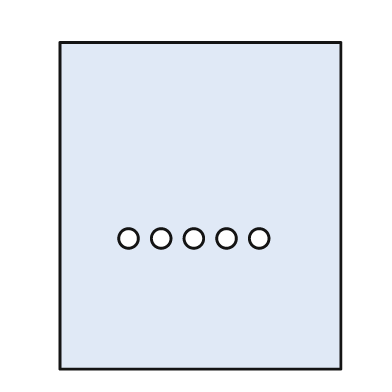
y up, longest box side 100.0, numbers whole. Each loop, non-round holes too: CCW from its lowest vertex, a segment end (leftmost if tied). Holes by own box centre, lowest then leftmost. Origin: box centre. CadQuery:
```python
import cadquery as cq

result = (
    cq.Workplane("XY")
    .moveTo(-43.0, -50.0)
    .lineTo(43.0, -50.0)
    .lineTo(43.0, 50.0)
    .lineTo(-43.0, 50.0)
    .close()
    .moveTo(-22.0, -10.0)
    .circle(3.0)
    .moveTo(-12.0, -10.0)
    .circle(3.0)
    .moveTo(-2.0, -10.0)
    .circle(3.0)
    .moveTo(8.0, -10.0)
    .circle(3.0)
    .moveTo(18.0, -10.0)
    .circle(3.0)
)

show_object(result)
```